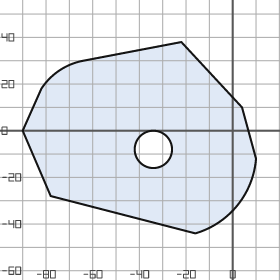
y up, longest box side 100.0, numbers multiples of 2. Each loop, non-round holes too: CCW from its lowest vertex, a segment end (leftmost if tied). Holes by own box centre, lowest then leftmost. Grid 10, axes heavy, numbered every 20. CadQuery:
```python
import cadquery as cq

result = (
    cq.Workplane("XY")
    .moveTo(-16.0, -44.0)
    .threePointArc((2.0, -32.0), (10.0, -12.0))
    .lineTo(4.0, 10.0)
    .lineTo(-22.0, 38.0)
    .lineTo(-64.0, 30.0)
    .threePointArc((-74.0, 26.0), (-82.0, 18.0))
    .lineTo(-90.0, 0.0)
    .lineTo(-78.0, -28.0)
    .close()
    .moveTo(-34.0, -8.0)
    .circle(8.0)
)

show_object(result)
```